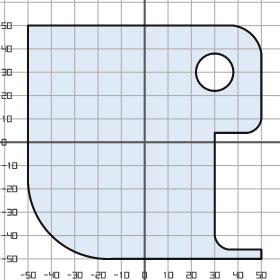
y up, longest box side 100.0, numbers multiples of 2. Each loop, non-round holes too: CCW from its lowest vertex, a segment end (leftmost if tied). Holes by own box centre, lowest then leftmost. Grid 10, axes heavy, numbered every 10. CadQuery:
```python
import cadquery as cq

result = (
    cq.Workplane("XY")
    .moveTo(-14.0, -50.0)
    .lineTo(50.0, -50.0)
    .lineTo(50.0, -46.0)
    .lineTo(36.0, -46.0)
    .threePointArc((32.0, -44.0), (30.0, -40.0))
    .lineTo(30.0, 4.0)
    .lineTo(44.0, 4.0)
    .threePointArc((48.0, 6.0), (50.0, 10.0))
    .lineTo(50.0, 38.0)
    .threePointArc((46.0, 46.0), (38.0, 50.0))
    .lineTo(-50.0, 50.0)
    .lineTo(-50.0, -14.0)
    .threePointArc((-40.0, -40.0), (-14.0, -50.0))
    .close()
    .moveTo(30.0, 30.0)
    .circle(8.0)
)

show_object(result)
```